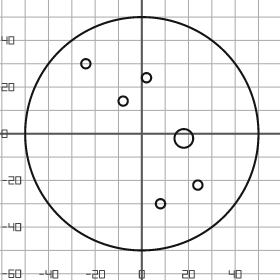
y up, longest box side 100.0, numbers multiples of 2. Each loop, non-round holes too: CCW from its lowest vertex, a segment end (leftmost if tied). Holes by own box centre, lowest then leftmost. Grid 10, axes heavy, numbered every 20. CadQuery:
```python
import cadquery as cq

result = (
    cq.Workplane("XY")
    .moveTo(0.0, 0.0)
    .circle(50.0)
    .moveTo(8.0, -30.0)
    .circle(2.0)
    .moveTo(24.0, -22.0)
    .circle(2.0)
    .moveTo(18.0, -2.0)
    .circle(4.0)
    .moveTo(-8.0, 14.0)
    .circle(2.0)
    .moveTo(2.0, 24.0)
    .circle(2.0)
    .moveTo(-24.0, 30.0)
    .circle(2.0)
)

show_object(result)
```